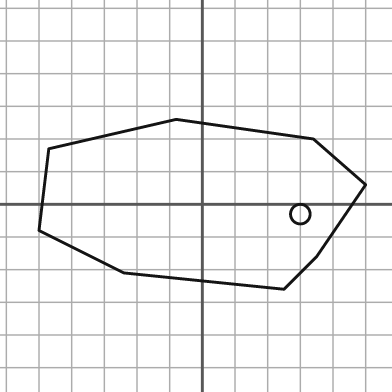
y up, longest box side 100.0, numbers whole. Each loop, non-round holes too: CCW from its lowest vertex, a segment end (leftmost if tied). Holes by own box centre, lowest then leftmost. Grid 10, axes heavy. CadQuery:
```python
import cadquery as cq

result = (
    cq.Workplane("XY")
    .moveTo(25.0, -26.0)
    .lineTo(35.0, -16.0)
    .lineTo(50.0, 6.0)
    .lineTo(34.0, 20.0)
    .lineTo(-8.0, 26.0)
    .lineTo(-47.0, 17.0)
    .lineTo(-50.0, -8.0)
    .lineTo(-24.0, -21.0)
    .close()
    .moveTo(30.0, -3.0)
    .circle(3.0)
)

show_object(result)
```